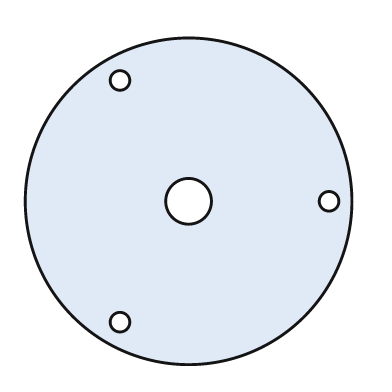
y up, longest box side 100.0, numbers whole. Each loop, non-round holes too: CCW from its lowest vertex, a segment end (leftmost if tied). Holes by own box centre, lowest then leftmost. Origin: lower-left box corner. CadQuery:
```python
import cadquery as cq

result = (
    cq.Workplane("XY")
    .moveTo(50.0, 50.0)
    .circle(50.0)
    .moveTo(29.0, 13.0)
    .circle(3.0)
    .moveTo(50.0, 50.0)
    .circle(7.0)
    .moveTo(93.0, 50.0)
    .circle(3.0)
    .moveTo(29.0, 87.0)
    .circle(3.0)
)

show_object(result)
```